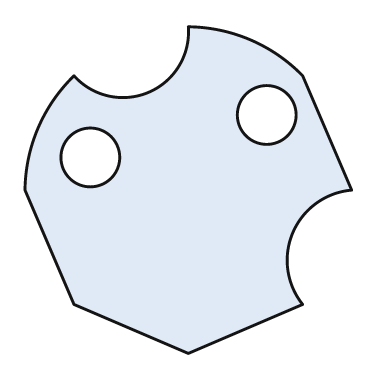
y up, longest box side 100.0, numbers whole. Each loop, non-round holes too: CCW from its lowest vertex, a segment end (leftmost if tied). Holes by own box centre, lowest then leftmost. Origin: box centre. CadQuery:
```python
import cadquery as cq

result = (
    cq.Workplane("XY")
    .moveTo(0.0, -50.0)
    .lineTo(35.0, -35.0)
    .threePointArc((32.0, -13.0), (50.0, 0.0))
    .lineTo(35.0, 35.0)
    .threePointArc((19.0, 46.0), (0.0, 50.0))
    .threePointArc((-12.0, 30.0), (-35.0, 35.0))
    .threePointArc((-46.0, 19.0), (-50.0, 0.0))
    .lineTo(-35.0, -35.0)
    .close()
    .moveTo(-30.0, 10.0)
    .circle(9.0)
    .moveTo(24.0, 23.0)
    .circle(9.0)
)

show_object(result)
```